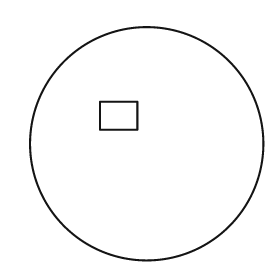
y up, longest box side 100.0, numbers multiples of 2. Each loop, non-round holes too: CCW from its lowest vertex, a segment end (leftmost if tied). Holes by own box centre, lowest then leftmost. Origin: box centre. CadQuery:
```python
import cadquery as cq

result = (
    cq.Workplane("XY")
    .moveTo(0.0, 0.0)
    .circle(50.0)
    .moveTo(-20.0, 6.0)
    .lineTo(-4.0, 6.0)
    .lineTo(-4.0, 18.0)
    .lineTo(-20.0, 18.0)
    .close()
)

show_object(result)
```